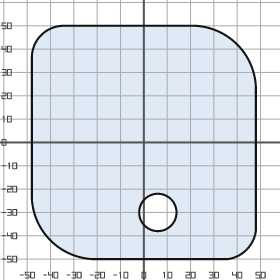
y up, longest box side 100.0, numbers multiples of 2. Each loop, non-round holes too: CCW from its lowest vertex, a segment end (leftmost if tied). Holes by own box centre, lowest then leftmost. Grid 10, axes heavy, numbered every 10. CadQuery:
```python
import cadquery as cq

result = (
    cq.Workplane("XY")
    .moveTo(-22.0, -50.0)
    .lineTo(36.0, -50.0)
    .threePointArc((44.0, -46.0), (48.0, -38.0))
    .lineTo(48.0, 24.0)
    .threePointArc((40.0, 42.0), (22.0, 50.0))
    .lineTo(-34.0, 50.0)
    .threePointArc((-44.0, 46.0), (-48.0, 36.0))
    .lineTo(-48.0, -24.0)
    .threePointArc((-40.0, -42.0), (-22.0, -50.0))
    .close()
    .moveTo(6.0, -30.0)
    .circle(8.0)
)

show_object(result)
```